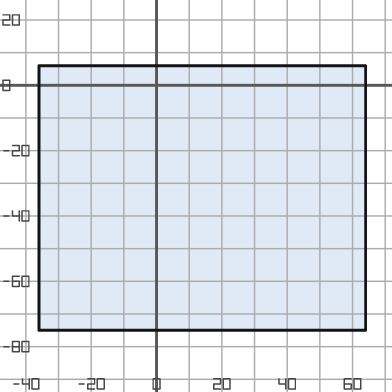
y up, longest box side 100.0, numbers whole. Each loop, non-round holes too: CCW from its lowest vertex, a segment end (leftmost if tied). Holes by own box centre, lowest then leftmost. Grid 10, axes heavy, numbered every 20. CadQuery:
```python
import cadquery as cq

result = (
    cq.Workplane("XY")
    .moveTo(-36.0, -75.0)
    .lineTo(64.0, -75.0)
    .lineTo(64.0, 6.0)
    .lineTo(-36.0, 6.0)
    .close()
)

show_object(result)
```